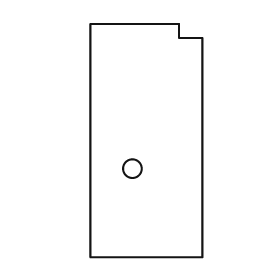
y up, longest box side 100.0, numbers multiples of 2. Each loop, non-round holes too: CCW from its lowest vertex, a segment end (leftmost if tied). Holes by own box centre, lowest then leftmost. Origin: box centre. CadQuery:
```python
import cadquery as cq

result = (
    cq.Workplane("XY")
    .moveTo(-24.0, -50.0)
    .lineTo(24.0, -50.0)
    .lineTo(24.0, 44.0)
    .lineTo(14.0, 44.0)
    .lineTo(14.0, 50.0)
    .lineTo(-24.0, 50.0)
    .close()
    .moveTo(-6.0, -12.0)
    .circle(4.0)
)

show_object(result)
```